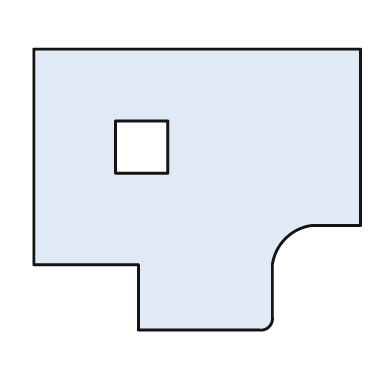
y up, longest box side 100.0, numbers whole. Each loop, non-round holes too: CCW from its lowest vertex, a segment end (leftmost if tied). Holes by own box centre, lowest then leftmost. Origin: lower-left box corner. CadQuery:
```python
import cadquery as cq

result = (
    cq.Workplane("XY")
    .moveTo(32.0, 0.0)
    .lineTo(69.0, 0.0)
    .threePointArc((72.0, 1.0), (73.0, 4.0))
    .lineTo(73.0, 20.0)
    .threePointArc((77.0, 28.0), (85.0, 32.0))
    .lineTo(100.0, 32.0)
    .lineTo(100.0, 86.0)
    .lineTo(0.0, 86.0)
    .lineTo(0.0, 20.0)
    .lineTo(32.0, 20.0)
    .close()
    .moveTo(25.0, 48.0)
    .lineTo(41.0, 48.0)
    .lineTo(41.0, 64.0)
    .lineTo(25.0, 64.0)
    .close()
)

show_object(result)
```